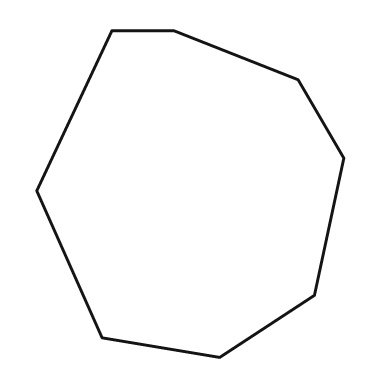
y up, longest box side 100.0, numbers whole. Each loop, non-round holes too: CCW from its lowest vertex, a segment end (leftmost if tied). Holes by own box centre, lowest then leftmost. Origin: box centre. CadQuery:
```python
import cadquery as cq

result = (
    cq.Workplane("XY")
    .moveTo(9.0, -50.0)
    .lineTo(38.0, -31.0)
    .lineTo(47.0, 11.0)
    .lineTo(33.0, 35.0)
    .lineTo(-5.0, 50.0)
    .lineTo(-24.0, 50.0)
    .lineTo(-47.0, 1.0)
    .lineTo(-27.0, -44.0)
    .close()
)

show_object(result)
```